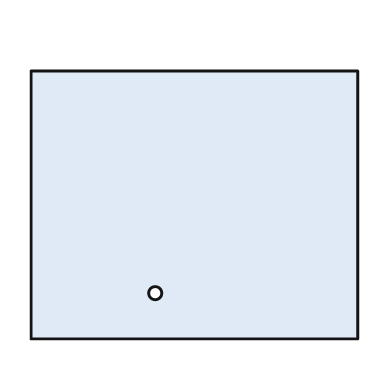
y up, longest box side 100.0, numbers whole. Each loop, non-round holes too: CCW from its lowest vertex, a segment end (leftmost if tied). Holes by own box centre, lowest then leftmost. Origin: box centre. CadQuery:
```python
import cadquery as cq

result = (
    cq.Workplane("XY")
    .moveTo(-50.0, -41.0)
    .lineTo(50.0, -41.0)
    .lineTo(50.0, 41.0)
    .lineTo(-50.0, 41.0)
    .close()
    .moveTo(-12.0, -27.0)
    .circle(2.0)
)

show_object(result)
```